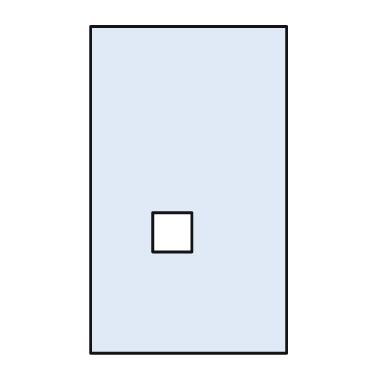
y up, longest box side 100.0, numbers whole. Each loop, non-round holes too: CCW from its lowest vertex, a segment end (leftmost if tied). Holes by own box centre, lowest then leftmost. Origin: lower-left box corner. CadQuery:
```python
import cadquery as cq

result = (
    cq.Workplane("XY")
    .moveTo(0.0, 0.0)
    .lineTo(60.0, 0.0)
    .lineTo(60.0, 100.0)
    .lineTo(0.0, 100.0)
    .close()
    .moveTo(19.0, 31.0)
    .lineTo(31.0, 31.0)
    .lineTo(31.0, 43.0)
    .lineTo(19.0, 43.0)
    .close()
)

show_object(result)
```